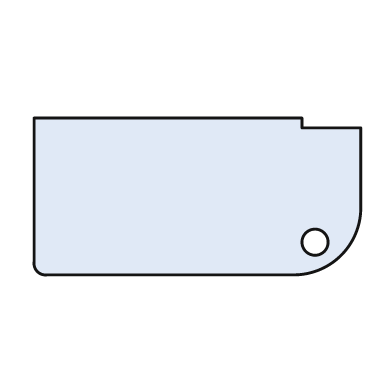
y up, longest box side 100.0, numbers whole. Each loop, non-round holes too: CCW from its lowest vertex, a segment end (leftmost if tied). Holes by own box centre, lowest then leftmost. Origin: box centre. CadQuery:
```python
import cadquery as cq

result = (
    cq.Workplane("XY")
    .moveTo(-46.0, -24.0)
    .lineTo(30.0, -24.0)
    .threePointArc((44.0, -18.0), (50.0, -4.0))
    .lineTo(50.0, 21.0)
    .lineTo(32.0, 21.0)
    .lineTo(32.0, 24.0)
    .lineTo(-50.0, 24.0)
    .lineTo(-50.0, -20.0)
    .threePointArc((-49.0, -23.0), (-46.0, -24.0))
    .close()
    .moveTo(36.0, -14.0)
    .circle(4.0)
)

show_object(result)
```